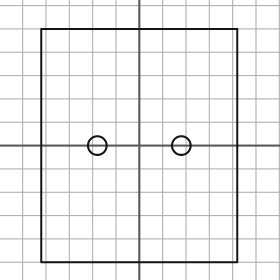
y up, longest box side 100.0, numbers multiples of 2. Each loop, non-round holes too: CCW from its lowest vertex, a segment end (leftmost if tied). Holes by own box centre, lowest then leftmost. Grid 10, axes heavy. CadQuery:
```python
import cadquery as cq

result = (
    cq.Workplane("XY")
    .moveTo(-42.0, -50.0)
    .lineTo(42.0, -50.0)
    .lineTo(42.0, 50.0)
    .lineTo(-42.0, 50.0)
    .close()
    .moveTo(-18.0, 0.0)
    .circle(4.0)
    .moveTo(18.0, 0.0)
    .circle(4.0)
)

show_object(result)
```